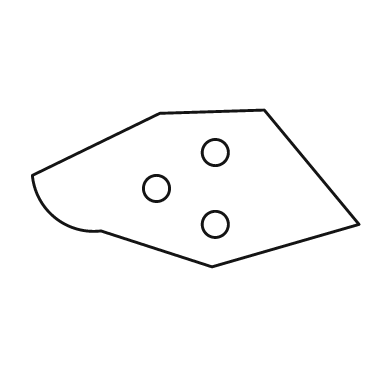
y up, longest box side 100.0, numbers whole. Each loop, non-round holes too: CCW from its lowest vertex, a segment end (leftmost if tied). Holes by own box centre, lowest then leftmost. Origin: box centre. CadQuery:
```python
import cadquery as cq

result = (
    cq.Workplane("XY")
    .moveTo(5.0, -24.0)
    .lineTo(50.0, -11.0)
    .lineTo(21.0, 24.0)
    .lineTo(-11.0, 23.0)
    .lineTo(-50.0, 4.0)
    .threePointArc((-43.0, -9.0), (-29.0, -13.0))
    .close()
    .moveTo(6.0, -11.0)
    .circle(4.0)
    .moveTo(-12.0, 0.0)
    .circle(4.0)
    .moveTo(6.0, 11.0)
    .circle(4.0)
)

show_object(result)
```